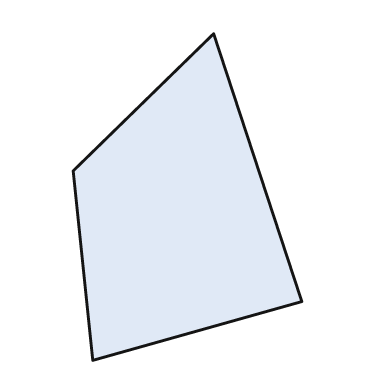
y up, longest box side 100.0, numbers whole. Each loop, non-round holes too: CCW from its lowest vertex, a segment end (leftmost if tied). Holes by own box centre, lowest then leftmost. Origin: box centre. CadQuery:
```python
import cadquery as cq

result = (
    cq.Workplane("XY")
    .moveTo(-29.0, -50.0)
    .lineTo(35.0, -32.0)
    .lineTo(8.0, 50.0)
    .lineTo(-35.0, 8.0)
    .close()
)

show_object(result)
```